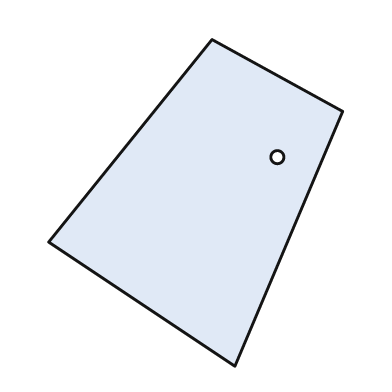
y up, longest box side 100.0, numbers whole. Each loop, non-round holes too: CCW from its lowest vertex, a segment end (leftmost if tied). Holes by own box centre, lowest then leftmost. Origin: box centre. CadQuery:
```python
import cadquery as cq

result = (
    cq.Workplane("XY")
    .moveTo(12.0, -50.0)
    .lineTo(45.0, 28.0)
    .lineTo(5.0, 50.0)
    .lineTo(-45.0, -12.0)
    .close()
    .moveTo(25.0, 14.0)
    .circle(2.0)
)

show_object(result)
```